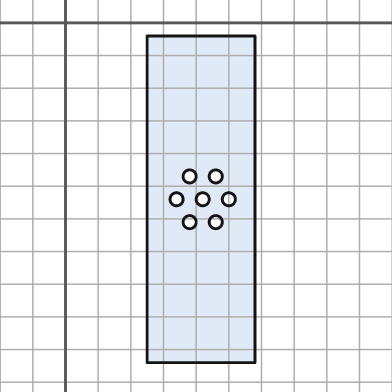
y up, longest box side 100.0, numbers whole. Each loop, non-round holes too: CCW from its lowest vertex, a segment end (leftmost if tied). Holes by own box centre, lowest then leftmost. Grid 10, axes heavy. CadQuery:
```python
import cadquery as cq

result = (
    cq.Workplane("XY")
    .moveTo(25.0, -104.0)
    .lineTo(58.0, -104.0)
    .lineTo(58.0, -4.0)
    .lineTo(25.0, -4.0)
    .close()
    .moveTo(38.0, -61.0)
    .circle(2.0)
    .moveTo(46.0, -61.0)
    .circle(2.0)
    .moveTo(34.0, -54.0)
    .circle(2.0)
    .moveTo(42.0, -54.0)
    .circle(2.0)
    .moveTo(50.0, -54.0)
    .circle(2.0)
    .moveTo(38.0, -47.0)
    .circle(2.0)
    .moveTo(46.0, -47.0)
    .circle(2.0)
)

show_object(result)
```